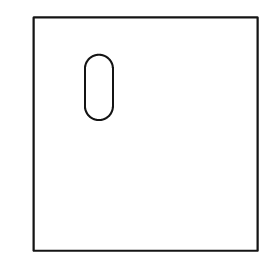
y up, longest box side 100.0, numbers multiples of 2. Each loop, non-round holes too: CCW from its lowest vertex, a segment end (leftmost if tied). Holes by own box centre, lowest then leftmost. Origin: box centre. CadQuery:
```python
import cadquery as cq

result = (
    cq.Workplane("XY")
    .moveTo(-48.0, -50.0)
    .lineTo(48.0, -50.0)
    .lineTo(48.0, 50.0)
    .lineTo(-48.0, 50.0)
    .close()
    .moveTo(-26.0, 12.0)
    .threePointArc((-20.0, 6.0), (-14.0, 12.0))
    .lineTo(-14.0, 28.0)
    .threePointArc((-20.0, 34.0), (-26.0, 28.0))
    .close()
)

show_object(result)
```